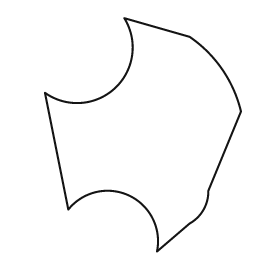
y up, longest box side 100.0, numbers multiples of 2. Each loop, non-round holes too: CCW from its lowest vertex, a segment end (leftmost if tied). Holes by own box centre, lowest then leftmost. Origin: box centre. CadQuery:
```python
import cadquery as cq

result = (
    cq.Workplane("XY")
    .moveTo(6.0, -50.0)
    .lineTo(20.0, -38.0)
    .threePointArc((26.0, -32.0), (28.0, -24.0))
    .lineTo(42.0, 10.0)
    .threePointArc((34.0, 28.0), (20.0, 42.0))
    .lineTo(-8.0, 50.0)
    .threePointArc((-12.0, 20.0), (-42.0, 18.0))
    .lineTo(-32.0, -32.0)
    .threePointArc((-6.0, -26.0), (6.0, -50.0))
    .close()
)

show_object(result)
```